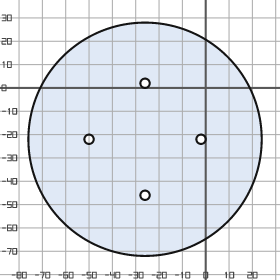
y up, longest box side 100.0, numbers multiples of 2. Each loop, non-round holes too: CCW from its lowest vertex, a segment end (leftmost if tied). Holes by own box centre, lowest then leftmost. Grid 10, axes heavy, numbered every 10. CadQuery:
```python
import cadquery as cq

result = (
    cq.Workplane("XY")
    .moveTo(-26.0, -22.0)
    .circle(50.0)
    .moveTo(-26.0, -46.0)
    .circle(2.0)
    .moveTo(-50.0, -22.0)
    .circle(2.0)
    .moveTo(-2.0, -22.0)
    .circle(2.0)
    .moveTo(-26.0, 2.0)
    .circle(2.0)
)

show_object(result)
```